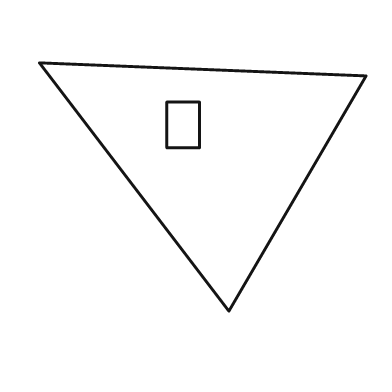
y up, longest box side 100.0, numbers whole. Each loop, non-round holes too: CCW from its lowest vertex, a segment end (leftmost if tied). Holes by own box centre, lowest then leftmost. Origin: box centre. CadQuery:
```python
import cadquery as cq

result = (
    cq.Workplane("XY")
    .moveTo(8.0, -38.0)
    .lineTo(50.0, 34.0)
    .lineTo(-50.0, 38.0)
    .close()
    .moveTo(-11.0, 12.0)
    .lineTo(-1.0, 12.0)
    .lineTo(-1.0, 26.0)
    .lineTo(-11.0, 26.0)
    .close()
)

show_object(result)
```